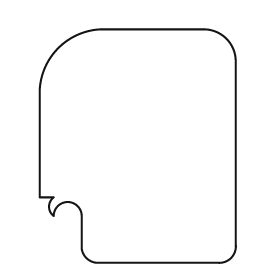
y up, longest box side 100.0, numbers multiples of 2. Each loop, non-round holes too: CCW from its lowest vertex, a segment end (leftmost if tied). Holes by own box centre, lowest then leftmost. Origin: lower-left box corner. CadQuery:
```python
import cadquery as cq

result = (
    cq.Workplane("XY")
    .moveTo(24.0, 0.0)
    .lineTo(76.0, 0.0)
    .threePointArc((82.0, 2.0), (84.0, 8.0))
    .lineTo(84.0, 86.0)
    .threePointArc((80.0, 96.0), (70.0, 100.0))
    .lineTo(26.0, 100.0)
    .threePointArc((8.0, 92.0), (0.0, 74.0))
    .lineTo(0.0, 28.0)
    .lineTo(6.0, 28.0)
    .threePointArc((4.0, 24.0), (6.0, 20.0))
    .threePointArc((12.0, 26.0), (18.0, 20.0))
    .lineTo(18.0, 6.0)
    .threePointArc((20.0, 2.0), (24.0, 0.0))
    .close()
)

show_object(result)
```